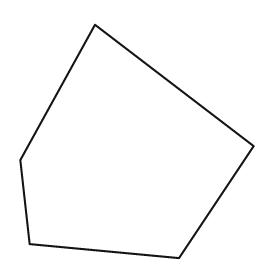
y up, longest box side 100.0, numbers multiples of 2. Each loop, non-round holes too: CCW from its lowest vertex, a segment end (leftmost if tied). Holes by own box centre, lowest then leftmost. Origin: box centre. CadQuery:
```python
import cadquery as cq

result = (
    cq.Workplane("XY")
    .moveTo(18.0, -50.0)
    .lineTo(50.0, -2.0)
    .lineTo(-18.0, 50.0)
    .lineTo(-50.0, -8.0)
    .lineTo(-46.0, -44.0)
    .close()
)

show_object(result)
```